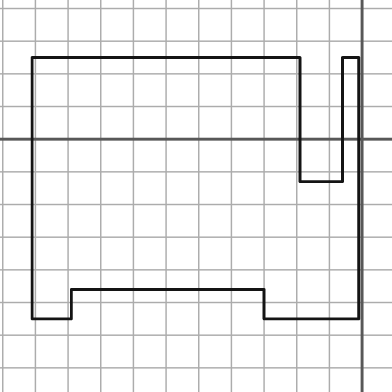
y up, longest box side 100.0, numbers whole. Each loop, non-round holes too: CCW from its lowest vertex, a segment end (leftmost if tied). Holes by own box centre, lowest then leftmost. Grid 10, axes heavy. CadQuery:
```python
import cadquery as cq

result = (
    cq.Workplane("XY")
    .moveTo(-101.0, -55.0)
    .lineTo(-89.0, -55.0)
    .lineTo(-89.0, -46.0)
    .lineTo(-30.0, -46.0)
    .lineTo(-30.0, -55.0)
    .lineTo(-1.0, -55.0)
    .lineTo(-1.0, 25.0)
    .lineTo(-6.0, 25.0)
    .lineTo(-6.0, -13.0)
    .lineTo(-19.0, -13.0)
    .lineTo(-19.0, 25.0)
    .lineTo(-101.0, 25.0)
    .close()
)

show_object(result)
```